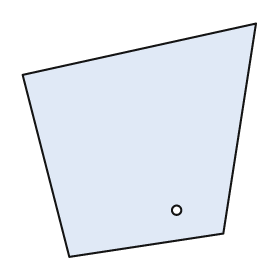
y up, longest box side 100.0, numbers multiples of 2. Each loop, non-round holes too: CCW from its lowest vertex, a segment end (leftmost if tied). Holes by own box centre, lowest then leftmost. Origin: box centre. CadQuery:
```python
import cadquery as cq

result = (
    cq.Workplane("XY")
    .moveTo(-30.0, -50.0)
    .lineTo(36.0, -40.0)
    .lineTo(50.0, 50.0)
    .lineTo(-50.0, 28.0)
    .close()
    .moveTo(16.0, -30.0)
    .circle(2.0)
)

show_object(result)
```